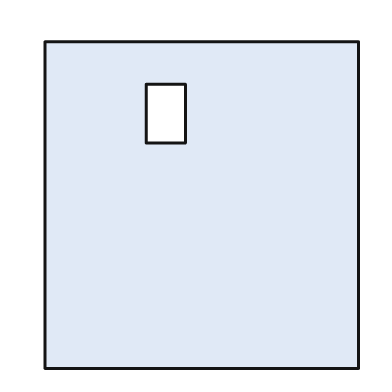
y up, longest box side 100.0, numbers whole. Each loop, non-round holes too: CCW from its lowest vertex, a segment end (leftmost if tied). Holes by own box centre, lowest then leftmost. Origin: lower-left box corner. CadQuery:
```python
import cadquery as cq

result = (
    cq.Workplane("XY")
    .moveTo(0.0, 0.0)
    .lineTo(96.0, 0.0)
    .lineTo(96.0, 100.0)
    .lineTo(0.0, 100.0)
    .close()
    .moveTo(31.0, 69.0)
    .lineTo(43.0, 69.0)
    .lineTo(43.0, 87.0)
    .lineTo(31.0, 87.0)
    .close()
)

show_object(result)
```